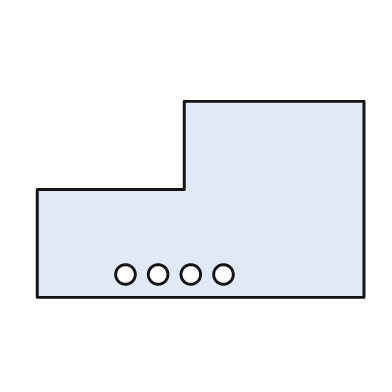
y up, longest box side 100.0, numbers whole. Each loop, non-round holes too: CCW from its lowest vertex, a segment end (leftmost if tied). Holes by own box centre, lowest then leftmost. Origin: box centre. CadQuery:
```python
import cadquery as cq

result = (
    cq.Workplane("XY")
    .moveTo(-50.0, -30.0)
    .lineTo(50.0, -30.0)
    .lineTo(50.0, 30.0)
    .lineTo(-5.0, 30.0)
    .lineTo(-5.0, 3.0)
    .lineTo(-50.0, 3.0)
    .close()
    .moveTo(-23.0, -23.0)
    .circle(3.0)
    .moveTo(-13.0, -23.0)
    .circle(3.0)
    .moveTo(-3.0, -23.0)
    .circle(3.0)
    .moveTo(7.0, -23.0)
    .circle(3.0)
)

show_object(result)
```